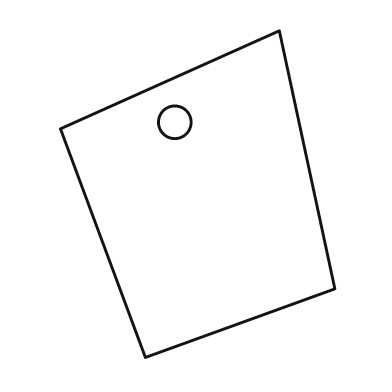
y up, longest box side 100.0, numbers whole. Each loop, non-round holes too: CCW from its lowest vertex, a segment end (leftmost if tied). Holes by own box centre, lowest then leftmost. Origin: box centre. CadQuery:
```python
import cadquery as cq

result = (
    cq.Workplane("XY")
    .moveTo(-16.0, -50.0)
    .lineTo(42.0, -29.0)
    .lineTo(25.0, 50.0)
    .lineTo(-42.0, 20.0)
    .close()
    .moveTo(-7.0, 22.0)
    .circle(5.0)
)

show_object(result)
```